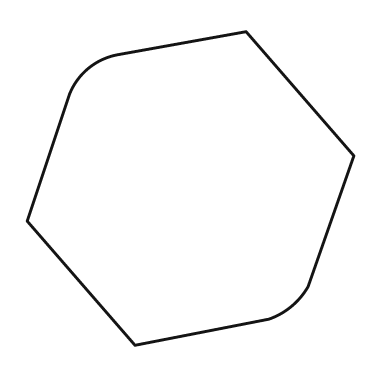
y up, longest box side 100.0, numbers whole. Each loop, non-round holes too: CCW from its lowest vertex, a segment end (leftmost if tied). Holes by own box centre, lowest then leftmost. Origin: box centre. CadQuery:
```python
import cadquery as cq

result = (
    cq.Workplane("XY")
    .moveTo(-17.0, -48.0)
    .lineTo(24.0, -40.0)
    .threePointArc((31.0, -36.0), (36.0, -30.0))
    .lineTo(50.0, 10.0)
    .lineTo(17.0, 48.0)
    .lineTo(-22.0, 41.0)
    .threePointArc((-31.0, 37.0), (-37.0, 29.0))
    .lineTo(-50.0, -10.0)
    .close()
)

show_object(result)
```